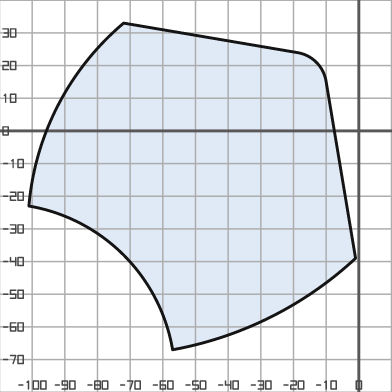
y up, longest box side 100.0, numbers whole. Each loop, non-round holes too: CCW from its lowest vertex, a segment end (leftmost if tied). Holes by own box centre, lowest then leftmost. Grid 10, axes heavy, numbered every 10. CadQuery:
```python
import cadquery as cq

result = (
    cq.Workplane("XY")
    .moveTo(-57.0, -67.0)
    .threePointArc((-27.0, -57.0), (-1.0, -39.0))
    .lineTo(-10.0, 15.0)
    .threePointArc((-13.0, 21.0), (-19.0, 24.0))
    .lineTo(-72.0, 33.0)
    .threePointArc((-92.0, 8.0), (-101.0, -23.0))
    .threePointArc((-72.0, -38.0), (-57.0, -67.0))
    .close()
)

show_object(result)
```